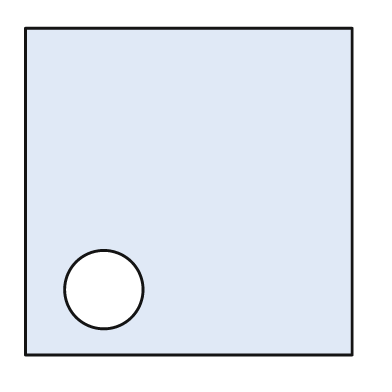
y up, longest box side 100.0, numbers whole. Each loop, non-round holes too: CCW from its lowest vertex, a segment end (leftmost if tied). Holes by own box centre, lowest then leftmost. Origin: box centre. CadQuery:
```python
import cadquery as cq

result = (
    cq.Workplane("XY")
    .moveTo(-50.0, -50.0)
    .lineTo(50.0, -50.0)
    .lineTo(50.0, 50.0)
    .lineTo(-50.0, 50.0)
    .close()
    .moveTo(-26.0, -30.0)
    .circle(12.0)
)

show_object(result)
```